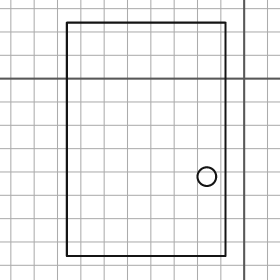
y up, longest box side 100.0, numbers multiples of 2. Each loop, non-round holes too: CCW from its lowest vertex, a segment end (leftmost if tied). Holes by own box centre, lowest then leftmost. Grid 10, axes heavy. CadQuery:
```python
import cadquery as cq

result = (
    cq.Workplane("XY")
    .moveTo(-76.0, -76.0)
    .lineTo(-8.0, -76.0)
    .lineTo(-8.0, 24.0)
    .lineTo(-76.0, 24.0)
    .close()
    .moveTo(-16.0, -42.0)
    .circle(4.0)
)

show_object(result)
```